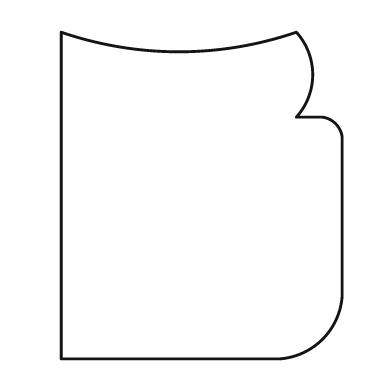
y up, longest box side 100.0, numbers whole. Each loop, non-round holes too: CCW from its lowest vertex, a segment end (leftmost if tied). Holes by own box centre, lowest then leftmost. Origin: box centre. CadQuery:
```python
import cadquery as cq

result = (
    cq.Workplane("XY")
    .moveTo(-43.0, -50.0)
    .lineTo(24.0, -50.0)
    .threePointArc((37.0, -44.0), (43.0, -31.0))
    .lineTo(43.0, 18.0)
    .threePointArc((41.0, 22.0), (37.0, 24.0))
    .lineTo(29.0, 24.0)
    .threePointArc((34.0, 37.0), (29.0, 50.0))
    .threePointArc((-7.0, 44.0), (-43.0, 50.0))
    .close()
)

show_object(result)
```